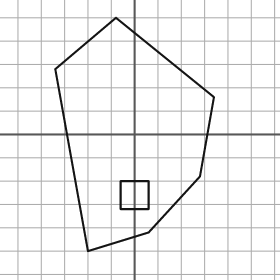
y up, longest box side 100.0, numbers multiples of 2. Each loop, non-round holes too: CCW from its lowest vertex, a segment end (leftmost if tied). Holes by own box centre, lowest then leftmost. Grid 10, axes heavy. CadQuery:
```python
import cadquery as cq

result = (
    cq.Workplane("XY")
    .moveTo(-20.0, -50.0)
    .lineTo(6.0, -42.0)
    .lineTo(28.0, -18.0)
    .lineTo(34.0, 16.0)
    .lineTo(-8.0, 50.0)
    .lineTo(-34.0, 28.0)
    .close()
    .moveTo(-6.0, -32.0)
    .lineTo(6.0, -32.0)
    .lineTo(6.0, -20.0)
    .lineTo(-6.0, -20.0)
    .close()
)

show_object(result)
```